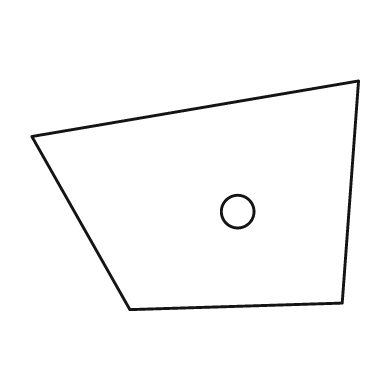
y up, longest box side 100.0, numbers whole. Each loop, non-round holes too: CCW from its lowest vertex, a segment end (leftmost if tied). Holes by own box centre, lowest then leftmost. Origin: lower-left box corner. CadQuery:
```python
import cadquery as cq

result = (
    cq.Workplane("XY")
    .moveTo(30.0, 0.0)
    .lineTo(95.0, 2.0)
    .lineTo(100.0, 70.0)
    .lineTo(0.0, 53.0)
    .close()
    .moveTo(63.0, 30.0)
    .circle(5.0)
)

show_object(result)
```